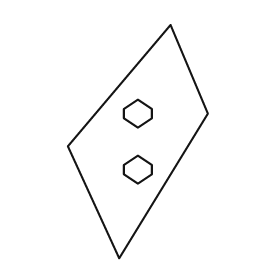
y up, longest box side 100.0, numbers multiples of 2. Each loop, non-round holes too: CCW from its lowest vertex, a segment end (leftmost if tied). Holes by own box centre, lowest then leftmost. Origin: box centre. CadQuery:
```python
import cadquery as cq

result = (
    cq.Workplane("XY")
    .moveTo(-8.0, -50.0)
    .lineTo(30.0, 12.0)
    .lineTo(14.0, 50.0)
    .lineTo(-30.0, -2.0)
    .close()
    .moveTo(0.0, -18.0)
    .lineTo(6.0, -14.0)
    .lineTo(6.0, -10.0)
    .lineTo(0.0, -6.0)
    .lineTo(-6.0, -10.0)
    .lineTo(-6.0, -14.0)
    .close()
    .moveTo(0.0, 6.0)
    .lineTo(6.0, 10.0)
    .lineTo(6.0, 14.0)
    .lineTo(0.0, 18.0)
    .lineTo(-6.0, 14.0)
    .lineTo(-6.0, 10.0)
    .close()
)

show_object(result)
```